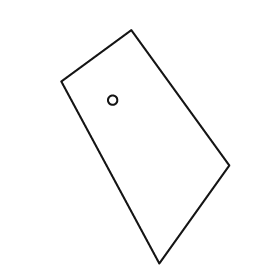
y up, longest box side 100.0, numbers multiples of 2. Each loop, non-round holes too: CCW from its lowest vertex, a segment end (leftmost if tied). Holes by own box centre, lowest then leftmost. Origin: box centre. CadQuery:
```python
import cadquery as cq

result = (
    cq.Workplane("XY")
    .moveTo(6.0, -50.0)
    .lineTo(36.0, -8.0)
    .lineTo(-6.0, 50.0)
    .lineTo(-36.0, 28.0)
    .close()
    .moveTo(-14.0, 20.0)
    .circle(2.0)
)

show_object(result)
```